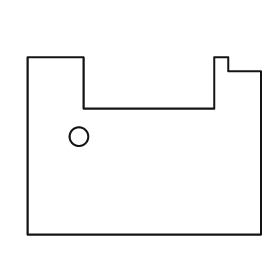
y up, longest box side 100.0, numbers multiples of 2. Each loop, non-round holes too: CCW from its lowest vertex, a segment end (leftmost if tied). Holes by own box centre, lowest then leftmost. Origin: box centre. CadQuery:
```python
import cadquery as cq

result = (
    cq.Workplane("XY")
    .moveTo(-50.0, -38.0)
    .lineTo(50.0, -38.0)
    .lineTo(50.0, 32.0)
    .lineTo(36.0, 32.0)
    .lineTo(36.0, 38.0)
    .lineTo(30.0, 38.0)
    .lineTo(30.0, 16.0)
    .lineTo(-26.0, 16.0)
    .lineTo(-26.0, 38.0)
    .lineTo(-50.0, 38.0)
    .close()
    .moveTo(-28.0, 4.0)
    .circle(4.0)
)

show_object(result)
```